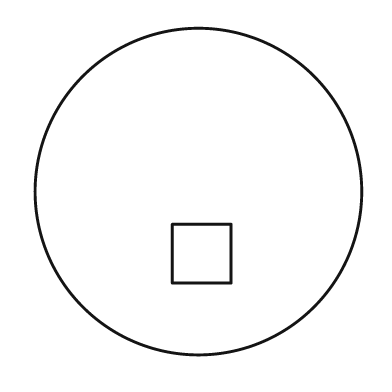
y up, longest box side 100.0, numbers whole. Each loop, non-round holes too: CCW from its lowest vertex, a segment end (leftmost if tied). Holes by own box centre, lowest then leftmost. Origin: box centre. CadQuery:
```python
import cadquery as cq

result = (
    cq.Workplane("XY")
    .moveTo(0.0, 0.0)
    .circle(50.0)
    .moveTo(-8.0, -28.0)
    .lineTo(10.0, -28.0)
    .lineTo(10.0, -10.0)
    .lineTo(-8.0, -10.0)
    .close()
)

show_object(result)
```